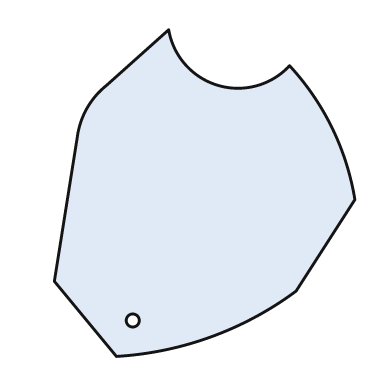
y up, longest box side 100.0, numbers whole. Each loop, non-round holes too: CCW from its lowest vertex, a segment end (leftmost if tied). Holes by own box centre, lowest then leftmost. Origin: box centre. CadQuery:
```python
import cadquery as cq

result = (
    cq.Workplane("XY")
    .moveTo(-27.0, -50.0)
    .threePointArc((2.0, -44.0), (28.0, -30.0))
    .lineTo(46.0, -2.0)
    .threePointArc((39.0, 20.0), (26.0, 39.0))
    .threePointArc((4.0, 33.0), (-11.0, 50.0))
    .lineTo(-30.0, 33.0)
    .threePointArc((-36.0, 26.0), (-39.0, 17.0))
    .lineTo(-46.0, -27.0)
    .close()
    .moveTo(-22.0, -39.0)
    .circle(2.0)
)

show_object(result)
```